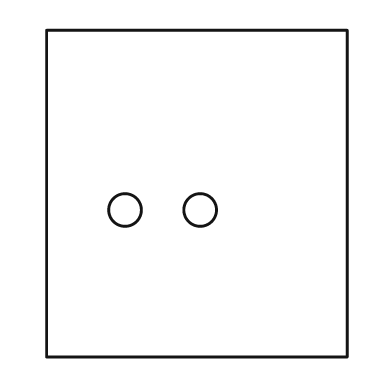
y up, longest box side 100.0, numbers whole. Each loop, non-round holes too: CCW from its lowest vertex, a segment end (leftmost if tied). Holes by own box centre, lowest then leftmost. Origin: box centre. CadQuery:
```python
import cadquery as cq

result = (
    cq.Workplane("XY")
    .moveTo(-46.0, -50.0)
    .lineTo(46.0, -50.0)
    .lineTo(46.0, 50.0)
    .lineTo(-46.0, 50.0)
    .close()
    .moveTo(-22.0, -5.0)
    .circle(5.0)
    .moveTo(1.0, -5.0)
    .circle(5.0)
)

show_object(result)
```